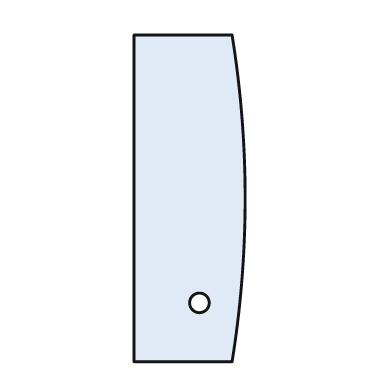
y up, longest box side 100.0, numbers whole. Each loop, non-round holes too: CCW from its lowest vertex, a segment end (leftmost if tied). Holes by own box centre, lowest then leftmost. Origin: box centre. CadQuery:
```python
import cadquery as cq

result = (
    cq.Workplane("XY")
    .moveTo(-17.0, -50.0)
    .lineTo(13.0, -50.0)
    .threePointArc((17.0, 0.0), (13.0, 50.0))
    .lineTo(-17.0, 50.0)
    .close()
    .moveTo(3.0, -32.0)
    .circle(3.0)
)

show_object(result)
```